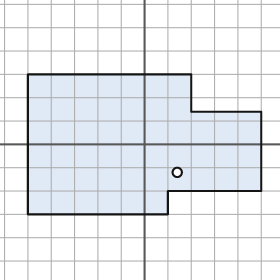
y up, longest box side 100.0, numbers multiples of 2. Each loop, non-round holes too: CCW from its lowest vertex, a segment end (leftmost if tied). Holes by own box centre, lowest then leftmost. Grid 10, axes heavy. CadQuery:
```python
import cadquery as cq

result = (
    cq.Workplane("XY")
    .moveTo(-50.0, -30.0)
    .lineTo(10.0, -30.0)
    .lineTo(10.0, -20.0)
    .lineTo(50.0, -20.0)
    .lineTo(50.0, 14.0)
    .lineTo(20.0, 14.0)
    .lineTo(20.0, 30.0)
    .lineTo(-50.0, 30.0)
    .close()
    .moveTo(14.0, -12.0)
    .circle(2.0)
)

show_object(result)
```